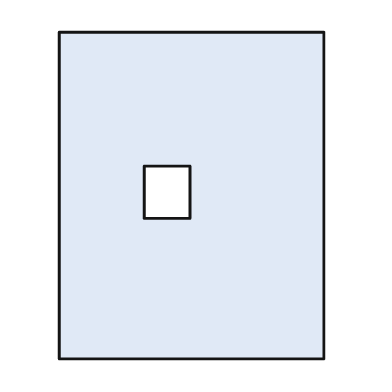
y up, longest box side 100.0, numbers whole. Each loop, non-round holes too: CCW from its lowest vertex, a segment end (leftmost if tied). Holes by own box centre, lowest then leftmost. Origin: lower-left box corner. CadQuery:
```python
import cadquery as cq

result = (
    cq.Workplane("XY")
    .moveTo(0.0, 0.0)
    .lineTo(81.0, 0.0)
    .lineTo(81.0, 100.0)
    .lineTo(0.0, 100.0)
    .close()
    .moveTo(26.0, 43.0)
    .lineTo(40.0, 43.0)
    .lineTo(40.0, 59.0)
    .lineTo(26.0, 59.0)
    .close()
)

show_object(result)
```